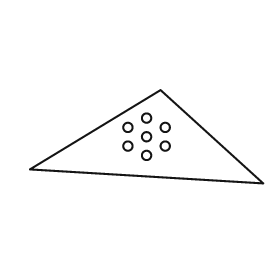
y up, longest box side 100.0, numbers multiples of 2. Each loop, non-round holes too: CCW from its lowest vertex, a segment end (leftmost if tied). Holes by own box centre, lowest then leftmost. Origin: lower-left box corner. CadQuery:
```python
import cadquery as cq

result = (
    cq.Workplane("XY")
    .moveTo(100.0, 0.0)
    .lineTo(56.0, 40.0)
    .lineTo(0.0, 6.0)
    .close()
    .moveTo(50.0, 12.0)
    .circle(2.0)
    .moveTo(42.0, 16.0)
    .circle(2.0)
    .moveTo(58.0, 16.0)
    .circle(2.0)
    .moveTo(50.0, 20.0)
    .circle(2.0)
    .moveTo(42.0, 24.0)
    .circle(2.0)
    .moveTo(58.0, 24.0)
    .circle(2.0)
    .moveTo(50.0, 28.0)
    .circle(2.0)
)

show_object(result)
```